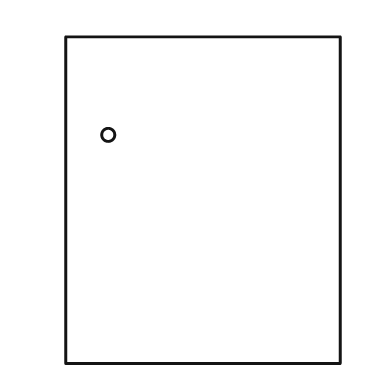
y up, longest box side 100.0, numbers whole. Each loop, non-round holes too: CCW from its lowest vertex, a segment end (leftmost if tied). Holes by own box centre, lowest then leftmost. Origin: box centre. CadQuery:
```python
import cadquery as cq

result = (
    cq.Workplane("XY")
    .moveTo(-42.0, -50.0)
    .lineTo(42.0, -50.0)
    .lineTo(42.0, 50.0)
    .lineTo(-42.0, 50.0)
    .close()
    .moveTo(-29.0, 20.0)
    .circle(2.0)
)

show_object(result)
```